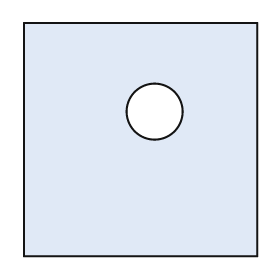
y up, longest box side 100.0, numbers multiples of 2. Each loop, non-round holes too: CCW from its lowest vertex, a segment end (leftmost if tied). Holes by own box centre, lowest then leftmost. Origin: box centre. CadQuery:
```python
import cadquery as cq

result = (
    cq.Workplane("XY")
    .moveTo(-50.0, -50.0)
    .lineTo(50.0, -50.0)
    .lineTo(50.0, 50.0)
    .lineTo(-50.0, 50.0)
    .close()
    .moveTo(6.0, 12.0)
    .circle(12.0)
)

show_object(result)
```